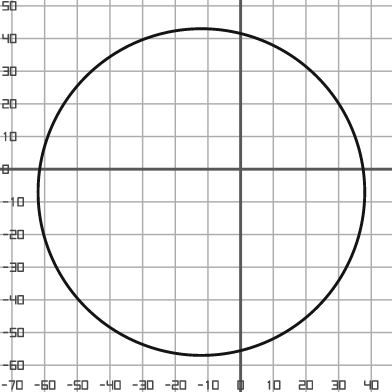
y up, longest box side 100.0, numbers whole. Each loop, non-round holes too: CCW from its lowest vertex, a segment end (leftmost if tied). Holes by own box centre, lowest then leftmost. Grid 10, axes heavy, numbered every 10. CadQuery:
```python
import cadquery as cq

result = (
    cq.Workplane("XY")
    .moveTo(-12.0, -7.0)
    .circle(50.0)
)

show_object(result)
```